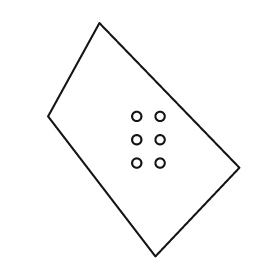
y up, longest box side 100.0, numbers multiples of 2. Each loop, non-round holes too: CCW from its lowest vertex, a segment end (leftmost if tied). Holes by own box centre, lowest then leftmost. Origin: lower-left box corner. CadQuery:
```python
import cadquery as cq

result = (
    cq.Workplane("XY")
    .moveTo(46.0, 0.0)
    .lineTo(82.0, 38.0)
    .lineTo(22.0, 100.0)
    .lineTo(0.0, 60.0)
    .close()
    .moveTo(38.0, 40.0)
    .circle(2.0)
    .moveTo(48.0, 40.0)
    .circle(2.0)
    .moveTo(38.0, 50.0)
    .circle(2.0)
    .moveTo(48.0, 50.0)
    .circle(2.0)
    .moveTo(38.0, 60.0)
    .circle(2.0)
    .moveTo(48.0, 60.0)
    .circle(2.0)
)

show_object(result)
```